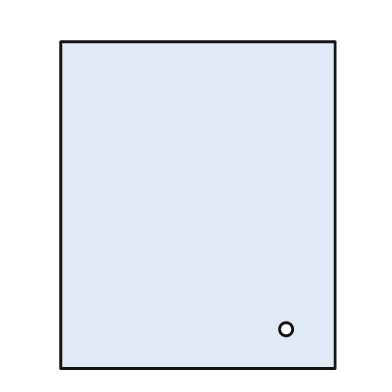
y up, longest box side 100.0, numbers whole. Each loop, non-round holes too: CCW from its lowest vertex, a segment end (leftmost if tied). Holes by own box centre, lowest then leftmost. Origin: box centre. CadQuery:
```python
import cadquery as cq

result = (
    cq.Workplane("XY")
    .moveTo(-42.0, -50.0)
    .lineTo(42.0, -50.0)
    .lineTo(42.0, 50.0)
    .lineTo(-42.0, 50.0)
    .close()
    .moveTo(27.0, -38.0)
    .circle(2.0)
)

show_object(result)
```